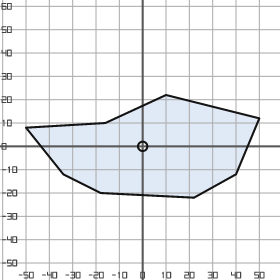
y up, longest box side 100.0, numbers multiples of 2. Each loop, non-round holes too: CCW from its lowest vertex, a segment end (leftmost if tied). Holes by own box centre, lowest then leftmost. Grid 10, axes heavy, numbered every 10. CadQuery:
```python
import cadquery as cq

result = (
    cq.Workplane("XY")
    .moveTo(22.0, -22.0)
    .lineTo(40.0, -12.0)
    .lineTo(50.0, 12.0)
    .lineTo(10.0, 22.0)
    .lineTo(-16.0, 10.0)
    .lineTo(-50.0, 8.0)
    .lineTo(-34.0, -12.0)
    .lineTo(-18.0, -20.0)
    .close()
    .moveTo(0.0, 0.0)
    .circle(2.0)
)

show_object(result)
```